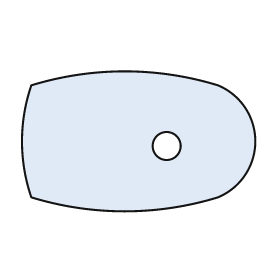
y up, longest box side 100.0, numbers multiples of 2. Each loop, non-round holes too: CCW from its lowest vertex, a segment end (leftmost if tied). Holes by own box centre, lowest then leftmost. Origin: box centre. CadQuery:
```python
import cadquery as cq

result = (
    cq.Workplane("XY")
    .moveTo(-46.0, -24.0)
    .threePointArc((-6.0, -30.0), (34.0, -24.0))
    .threePointArc((50.0, 0.0), (34.0, 24.0))
    .threePointArc((-6.0, 30.0), (-46.0, 24.0))
    .threePointArc((-50.0, 0.0), (-46.0, -24.0))
    .close()
    .moveTo(12.0, -2.0)
    .circle(6.0)
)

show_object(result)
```